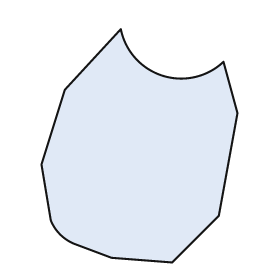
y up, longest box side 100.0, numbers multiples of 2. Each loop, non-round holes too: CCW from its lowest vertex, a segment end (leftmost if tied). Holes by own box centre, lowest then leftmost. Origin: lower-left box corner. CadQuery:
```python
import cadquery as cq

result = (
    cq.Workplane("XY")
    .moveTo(56.0, 0.0)
    .lineTo(76.0, 20.0)
    .lineTo(84.0, 64.0)
    .lineTo(78.0, 86.0)
    .threePointArc((52.0, 80.0), (34.0, 100.0))
    .lineTo(10.0, 74.0)
    .lineTo(0.0, 42.0)
    .lineTo(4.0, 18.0)
    .threePointArc((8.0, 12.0), (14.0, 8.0))
    .lineTo(30.0, 2.0)
    .close()
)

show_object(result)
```